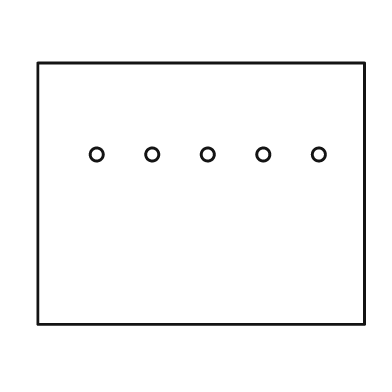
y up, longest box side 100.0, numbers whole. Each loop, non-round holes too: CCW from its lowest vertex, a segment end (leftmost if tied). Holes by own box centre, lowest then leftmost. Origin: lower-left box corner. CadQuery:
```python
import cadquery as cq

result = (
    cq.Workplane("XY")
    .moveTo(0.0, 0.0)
    .lineTo(100.0, 0.0)
    .lineTo(100.0, 80.0)
    .lineTo(0.0, 80.0)
    .close()
    .moveTo(18.0, 52.0)
    .circle(2.0)
    .moveTo(35.0, 52.0)
    .circle(2.0)
    .moveTo(52.0, 52.0)
    .circle(2.0)
    .moveTo(69.0, 52.0)
    .circle(2.0)
    .moveTo(86.0, 52.0)
    .circle(2.0)
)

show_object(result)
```